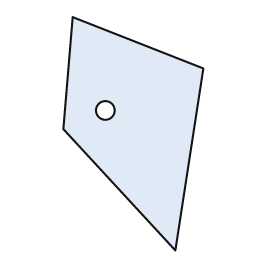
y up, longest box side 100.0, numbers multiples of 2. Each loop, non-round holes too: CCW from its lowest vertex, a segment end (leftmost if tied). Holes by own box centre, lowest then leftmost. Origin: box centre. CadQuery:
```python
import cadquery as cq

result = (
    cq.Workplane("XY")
    .moveTo(18.0, -50.0)
    .lineTo(30.0, 28.0)
    .lineTo(-26.0, 50.0)
    .lineTo(-30.0, 2.0)
    .close()
    .moveTo(-12.0, 10.0)
    .circle(4.0)
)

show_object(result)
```